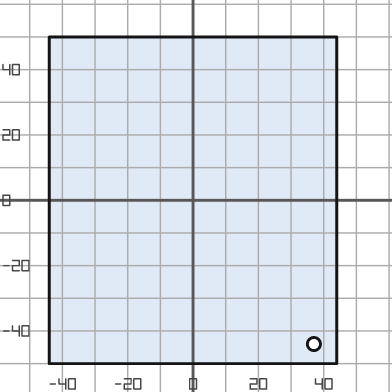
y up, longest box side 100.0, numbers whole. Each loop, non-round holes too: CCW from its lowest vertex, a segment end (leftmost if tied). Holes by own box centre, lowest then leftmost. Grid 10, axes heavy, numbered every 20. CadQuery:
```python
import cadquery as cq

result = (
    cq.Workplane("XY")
    .moveTo(-44.0, -50.0)
    .lineTo(44.0, -50.0)
    .lineTo(44.0, 50.0)
    .lineTo(-44.0, 50.0)
    .close()
    .moveTo(37.0, -44.0)
    .circle(2.0)
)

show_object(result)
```